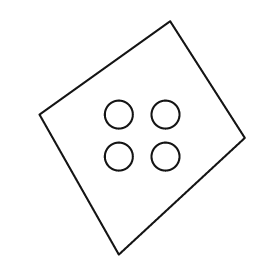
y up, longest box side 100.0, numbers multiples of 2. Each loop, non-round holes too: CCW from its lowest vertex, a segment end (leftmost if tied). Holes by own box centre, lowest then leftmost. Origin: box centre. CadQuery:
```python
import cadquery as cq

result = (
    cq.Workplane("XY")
    .moveTo(-10.0, -50.0)
    .lineTo(44.0, 0.0)
    .lineTo(12.0, 50.0)
    .lineTo(-44.0, 10.0)
    .close()
    .moveTo(-10.0, -8.0)
    .circle(6.0)
    .moveTo(10.0, -8.0)
    .circle(6.0)
    .moveTo(-10.0, 10.0)
    .circle(6.0)
    .moveTo(10.0, 10.0)
    .circle(6.0)
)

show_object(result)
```